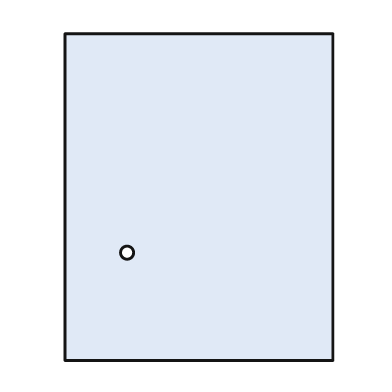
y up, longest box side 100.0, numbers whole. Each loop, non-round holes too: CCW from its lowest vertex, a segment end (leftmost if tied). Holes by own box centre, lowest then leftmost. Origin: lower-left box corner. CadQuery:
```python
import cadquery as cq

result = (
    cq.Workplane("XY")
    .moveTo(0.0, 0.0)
    .lineTo(82.0, 0.0)
    .lineTo(82.0, 100.0)
    .lineTo(0.0, 100.0)
    .close()
    .moveTo(19.0, 33.0)
    .circle(2.0)
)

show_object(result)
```